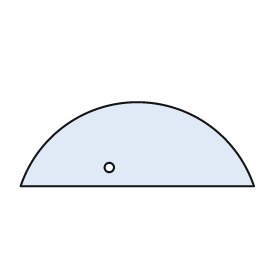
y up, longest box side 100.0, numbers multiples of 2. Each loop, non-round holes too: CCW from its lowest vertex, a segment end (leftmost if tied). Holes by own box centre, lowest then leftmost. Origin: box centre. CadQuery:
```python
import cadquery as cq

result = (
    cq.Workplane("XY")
    .moveTo(-50.0, -18.0)
    .lineTo(50.0, -18.0)
    .threePointArc((0.0, 18.0), (-50.0, -18.0))
    .close()
    .moveTo(-12.0, -10.0)
    .circle(2.0)
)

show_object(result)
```